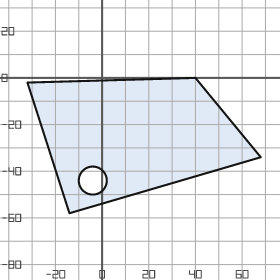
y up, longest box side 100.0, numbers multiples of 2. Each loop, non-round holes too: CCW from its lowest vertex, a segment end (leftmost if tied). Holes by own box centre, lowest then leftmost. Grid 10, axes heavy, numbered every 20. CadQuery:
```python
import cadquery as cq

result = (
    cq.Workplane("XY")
    .moveTo(-14.0, -58.0)
    .lineTo(68.0, -34.0)
    .lineTo(40.0, 0.0)
    .lineTo(-32.0, -2.0)
    .close()
    .moveTo(-4.0, -44.0)
    .circle(6.0)
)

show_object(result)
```